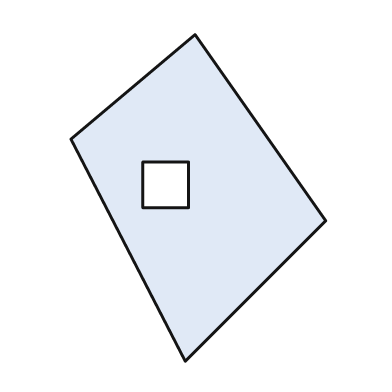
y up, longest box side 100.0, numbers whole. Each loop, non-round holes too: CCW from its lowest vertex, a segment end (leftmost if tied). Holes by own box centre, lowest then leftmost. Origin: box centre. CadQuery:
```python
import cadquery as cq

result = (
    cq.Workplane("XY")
    .moveTo(-4.0, -50.0)
    .lineTo(39.0, -7.0)
    .lineTo(-1.0, 50.0)
    .lineTo(-39.0, 18.0)
    .close()
    .moveTo(-17.0, -3.0)
    .lineTo(-3.0, -3.0)
    .lineTo(-3.0, 11.0)
    .lineTo(-17.0, 11.0)
    .close()
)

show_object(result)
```